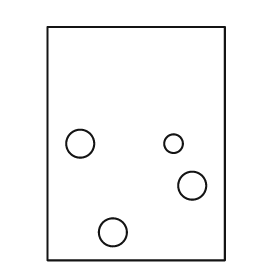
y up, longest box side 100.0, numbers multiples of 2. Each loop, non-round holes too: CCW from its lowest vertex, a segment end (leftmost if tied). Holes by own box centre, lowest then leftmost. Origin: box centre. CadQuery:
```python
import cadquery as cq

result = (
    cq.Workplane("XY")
    .moveTo(-38.0, -50.0)
    .lineTo(38.0, -50.0)
    .lineTo(38.0, 50.0)
    .lineTo(-38.0, 50.0)
    .close()
    .moveTo(-10.0, -38.0)
    .circle(6.0)
    .moveTo(24.0, -18.0)
    .circle(6.0)
    .moveTo(-24.0, 0.0)
    .circle(6.0)
    .moveTo(16.0, 0.0)
    .circle(4.0)
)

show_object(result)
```